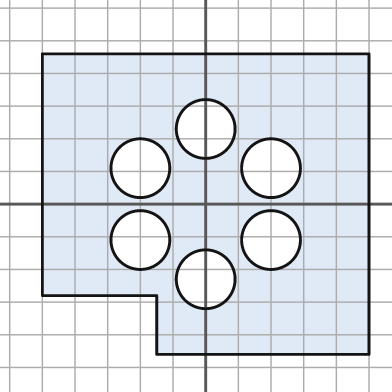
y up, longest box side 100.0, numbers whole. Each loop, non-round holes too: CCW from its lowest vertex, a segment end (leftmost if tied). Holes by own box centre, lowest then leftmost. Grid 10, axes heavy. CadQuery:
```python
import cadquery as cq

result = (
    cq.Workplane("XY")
    .moveTo(-15.0, -46.0)
    .lineTo(50.0, -46.0)
    .lineTo(50.0, 46.0)
    .lineTo(-50.0, 46.0)
    .lineTo(-50.0, -28.0)
    .lineTo(-15.0, -28.0)
    .close()
    .moveTo(0.0, -23.0)
    .circle(9.0)
    .moveTo(-20.0, -11.0)
    .circle(9.0)
    .moveTo(20.0, -11.0)
    .circle(9.0)
    .moveTo(-20.0, 11.0)
    .circle(9.0)
    .moveTo(20.0, 11.0)
    .circle(9.0)
    .moveTo(0.0, 23.0)
    .circle(9.0)
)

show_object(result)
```